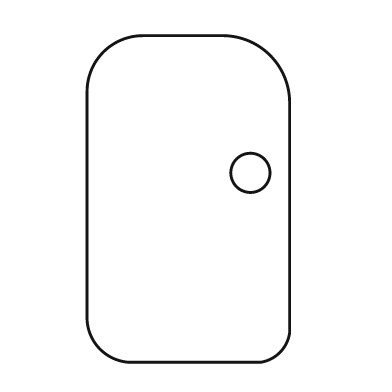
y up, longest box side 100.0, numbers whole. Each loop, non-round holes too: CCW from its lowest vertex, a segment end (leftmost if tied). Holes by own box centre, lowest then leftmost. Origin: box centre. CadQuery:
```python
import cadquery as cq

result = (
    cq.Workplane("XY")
    .moveTo(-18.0, -50.0)
    .lineTo(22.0, -50.0)
    .threePointArc((28.0, -47.0), (31.0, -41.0))
    .lineTo(31.0, 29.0)
    .threePointArc((25.0, 44.0), (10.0, 50.0))
    .lineTo(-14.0, 50.0)
    .threePointArc((-26.0, 45.0), (-31.0, 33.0))
    .lineTo(-31.0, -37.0)
    .threePointArc((-27.0, -46.0), (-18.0, -50.0))
    .close()
    .moveTo(19.0, 8.0)
    .circle(6.0)
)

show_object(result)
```